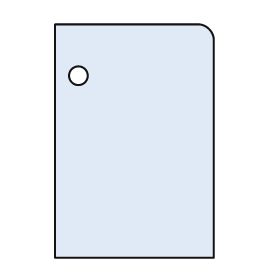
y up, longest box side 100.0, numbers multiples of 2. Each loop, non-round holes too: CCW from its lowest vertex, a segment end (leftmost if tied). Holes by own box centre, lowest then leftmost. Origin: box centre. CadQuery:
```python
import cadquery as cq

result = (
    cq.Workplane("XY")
    .moveTo(-34.0, -50.0)
    .lineTo(34.0, -50.0)
    .lineTo(34.0, 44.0)
    .threePointArc((32.0, 48.0), (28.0, 50.0))
    .lineTo(-34.0, 50.0)
    .close()
    .moveTo(-24.0, 28.0)
    .circle(4.0)
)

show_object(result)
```